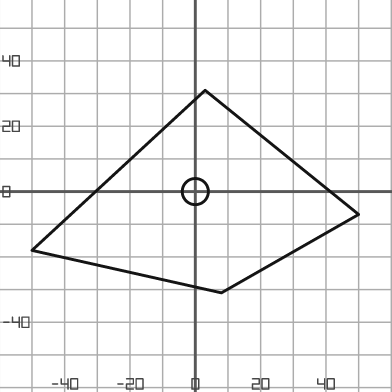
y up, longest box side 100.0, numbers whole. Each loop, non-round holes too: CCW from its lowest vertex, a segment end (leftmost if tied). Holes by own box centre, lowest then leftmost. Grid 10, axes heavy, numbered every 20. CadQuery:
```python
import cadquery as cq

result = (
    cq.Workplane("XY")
    .moveTo(8.0, -31.0)
    .lineTo(50.0, -7.0)
    .lineTo(3.0, 31.0)
    .lineTo(-50.0, -18.0)
    .close()
    .moveTo(0.0, 0.0)
    .circle(4.0)
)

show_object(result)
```